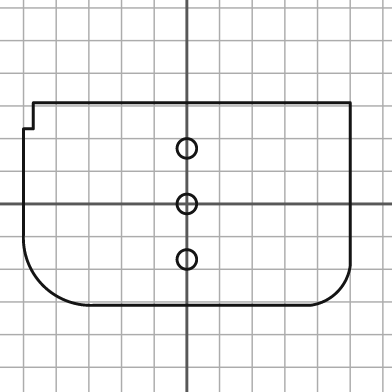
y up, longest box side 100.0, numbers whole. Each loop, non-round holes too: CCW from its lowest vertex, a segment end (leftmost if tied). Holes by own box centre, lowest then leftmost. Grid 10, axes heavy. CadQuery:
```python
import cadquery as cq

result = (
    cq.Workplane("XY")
    .moveTo(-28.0, -31.0)
    .lineTo(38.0, -31.0)
    .threePointArc((46.0, -27.0), (50.0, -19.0))
    .lineTo(50.0, 31.0)
    .lineTo(-47.0, 31.0)
    .lineTo(-47.0, 23.0)
    .lineTo(-50.0, 23.0)
    .lineTo(-50.0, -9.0)
    .threePointArc((-44.0, -25.0), (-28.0, -31.0))
    .close()
    .moveTo(0.0, -17.0)
    .circle(3.0)
    .moveTo(0.0, 0.0)
    .circle(3.0)
    .moveTo(0.0, 17.0)
    .circle(3.0)
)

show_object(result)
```